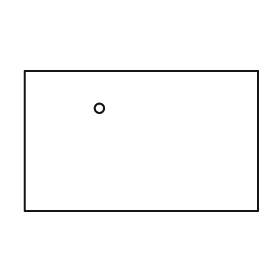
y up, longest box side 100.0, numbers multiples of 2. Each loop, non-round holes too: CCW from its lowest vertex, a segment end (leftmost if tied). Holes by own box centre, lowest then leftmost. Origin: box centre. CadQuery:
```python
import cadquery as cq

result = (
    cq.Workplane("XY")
    .moveTo(-50.0, -30.0)
    .lineTo(50.0, -30.0)
    .lineTo(50.0, 30.0)
    .lineTo(-50.0, 30.0)
    .close()
    .moveTo(-18.0, 14.0)
    .circle(2.0)
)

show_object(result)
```